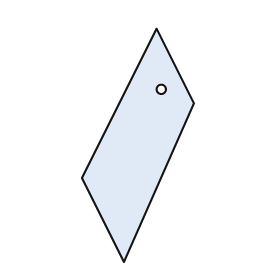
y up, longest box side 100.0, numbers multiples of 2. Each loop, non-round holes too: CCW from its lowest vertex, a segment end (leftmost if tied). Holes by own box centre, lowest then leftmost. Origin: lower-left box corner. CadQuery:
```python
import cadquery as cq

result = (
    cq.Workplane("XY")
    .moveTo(18.0, 0.0)
    .lineTo(48.0, 68.0)
    .lineTo(32.0, 100.0)
    .lineTo(0.0, 36.0)
    .close()
    .moveTo(34.0, 74.0)
    .circle(2.0)
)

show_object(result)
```